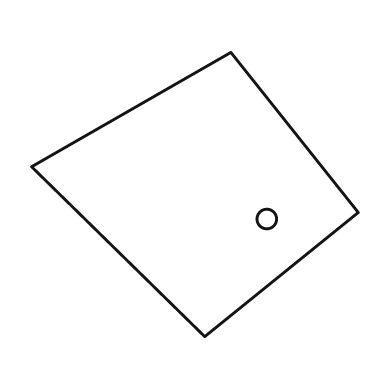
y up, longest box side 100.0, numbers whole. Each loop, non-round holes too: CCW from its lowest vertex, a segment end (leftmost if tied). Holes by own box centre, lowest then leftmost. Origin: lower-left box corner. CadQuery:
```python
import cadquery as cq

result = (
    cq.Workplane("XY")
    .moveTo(53.0, 0.0)
    .lineTo(100.0, 38.0)
    .lineTo(61.0, 87.0)
    .lineTo(0.0, 52.0)
    .close()
    .moveTo(72.0, 36.0)
    .circle(3.0)
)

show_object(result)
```